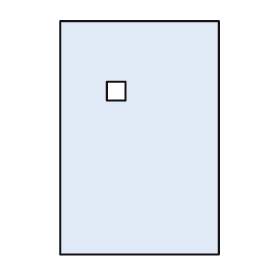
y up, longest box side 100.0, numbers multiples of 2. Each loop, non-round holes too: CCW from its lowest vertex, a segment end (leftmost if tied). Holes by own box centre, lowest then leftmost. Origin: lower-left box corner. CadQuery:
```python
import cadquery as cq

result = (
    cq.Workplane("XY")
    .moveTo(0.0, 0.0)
    .lineTo(68.0, 0.0)
    .lineTo(68.0, 100.0)
    .lineTo(0.0, 100.0)
    .close()
    .moveTo(20.0, 66.0)
    .lineTo(28.0, 66.0)
    .lineTo(28.0, 74.0)
    .lineTo(20.0, 74.0)
    .close()
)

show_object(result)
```